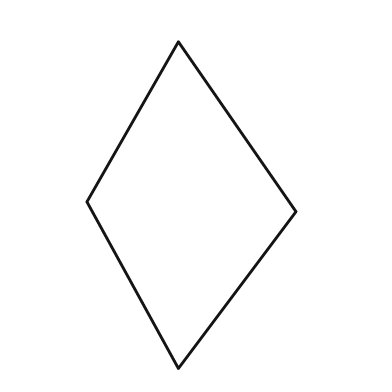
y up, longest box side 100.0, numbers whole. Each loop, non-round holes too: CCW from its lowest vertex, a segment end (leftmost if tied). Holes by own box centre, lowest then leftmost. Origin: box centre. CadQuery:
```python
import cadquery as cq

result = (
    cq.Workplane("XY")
    .moveTo(-4.0, -50.0)
    .lineTo(32.0, -2.0)
    .lineTo(-4.0, 50.0)
    .lineTo(-32.0, 1.0)
    .close()
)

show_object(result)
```